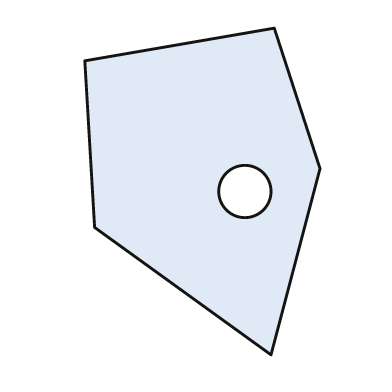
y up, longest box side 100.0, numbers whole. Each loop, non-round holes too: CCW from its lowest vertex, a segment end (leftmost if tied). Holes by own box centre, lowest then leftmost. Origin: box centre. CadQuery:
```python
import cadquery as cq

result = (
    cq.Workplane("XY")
    .moveTo(21.0, -50.0)
    .lineTo(36.0, 7.0)
    .lineTo(22.0, 50.0)
    .lineTo(-36.0, 40.0)
    .lineTo(-33.0, -11.0)
    .close()
    .moveTo(13.0, 0.0)
    .circle(8.0)
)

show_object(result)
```